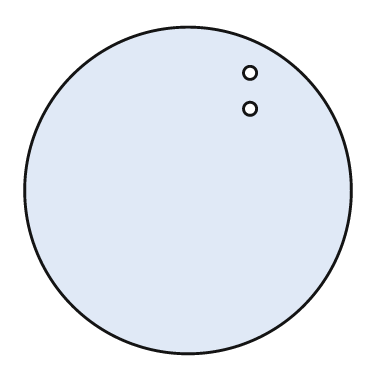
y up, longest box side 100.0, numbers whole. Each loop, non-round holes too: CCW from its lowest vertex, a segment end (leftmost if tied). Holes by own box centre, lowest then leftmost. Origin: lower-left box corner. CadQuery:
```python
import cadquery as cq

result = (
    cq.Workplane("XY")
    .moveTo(50.0, 50.0)
    .circle(50.0)
    .moveTo(69.0, 75.0)
    .circle(2.0)
    .moveTo(69.0, 86.0)
    .circle(2.0)
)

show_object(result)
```